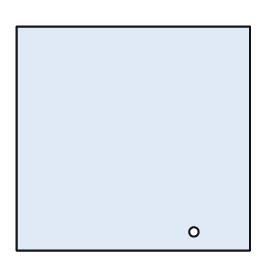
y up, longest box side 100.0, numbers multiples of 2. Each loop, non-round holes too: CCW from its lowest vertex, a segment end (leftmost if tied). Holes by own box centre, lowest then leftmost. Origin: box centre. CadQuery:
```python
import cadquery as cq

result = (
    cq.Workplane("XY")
    .moveTo(-50.0, -48.0)
    .lineTo(50.0, -48.0)
    .lineTo(50.0, 48.0)
    .lineTo(-50.0, 48.0)
    .close()
    .moveTo(26.0, -40.0)
    .circle(2.0)
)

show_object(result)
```